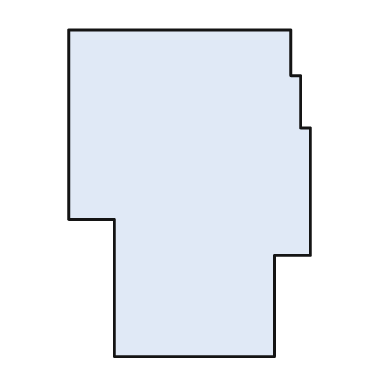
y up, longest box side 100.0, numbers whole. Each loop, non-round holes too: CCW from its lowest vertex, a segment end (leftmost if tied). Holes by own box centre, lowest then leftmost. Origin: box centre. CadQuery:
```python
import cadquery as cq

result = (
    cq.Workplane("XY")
    .moveTo(-23.0, -50.0)
    .lineTo(26.0, -50.0)
    .lineTo(26.0, -19.0)
    .lineTo(37.0, -19.0)
    .lineTo(37.0, 20.0)
    .lineTo(34.0, 20.0)
    .lineTo(34.0, 36.0)
    .lineTo(31.0, 36.0)
    .lineTo(31.0, 50.0)
    .lineTo(-37.0, 50.0)
    .lineTo(-37.0, -8.0)
    .lineTo(-23.0, -8.0)
    .close()
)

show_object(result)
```